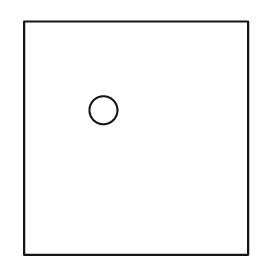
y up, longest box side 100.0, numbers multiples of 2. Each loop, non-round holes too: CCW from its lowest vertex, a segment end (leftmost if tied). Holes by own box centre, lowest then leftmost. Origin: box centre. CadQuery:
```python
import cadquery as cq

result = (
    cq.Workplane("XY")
    .moveTo(-48.0, -50.0)
    .lineTo(48.0, -50.0)
    .lineTo(48.0, 50.0)
    .lineTo(-48.0, 50.0)
    .close()
    .moveTo(-14.0, 12.0)
    .circle(6.0)
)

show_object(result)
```